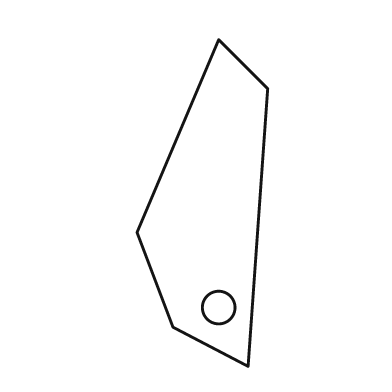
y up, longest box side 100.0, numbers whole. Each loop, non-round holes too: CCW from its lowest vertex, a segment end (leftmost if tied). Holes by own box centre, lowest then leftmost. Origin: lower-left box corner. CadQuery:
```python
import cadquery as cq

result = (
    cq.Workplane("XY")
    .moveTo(34.0, 0.0)
    .lineTo(40.0, 85.0)
    .lineTo(25.0, 100.0)
    .lineTo(0.0, 41.0)
    .lineTo(11.0, 12.0)
    .close()
    .moveTo(25.0, 18.0)
    .circle(5.0)
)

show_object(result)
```